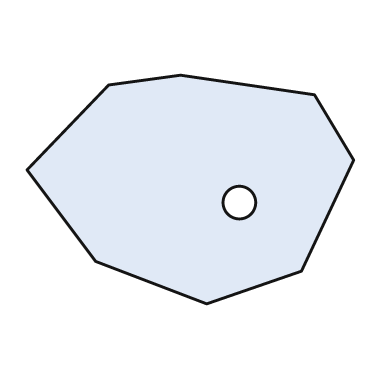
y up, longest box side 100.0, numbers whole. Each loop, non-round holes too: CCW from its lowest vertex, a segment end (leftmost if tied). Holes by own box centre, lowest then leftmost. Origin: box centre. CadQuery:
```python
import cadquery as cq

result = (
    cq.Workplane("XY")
    .moveTo(5.0, -35.0)
    .lineTo(34.0, -25.0)
    .lineTo(50.0, 9.0)
    .lineTo(38.0, 29.0)
    .lineTo(-3.0, 35.0)
    .lineTo(-25.0, 32.0)
    .lineTo(-50.0, 6.0)
    .lineTo(-29.0, -22.0)
    .close()
    .moveTo(15.0, -4.0)
    .circle(5.0)
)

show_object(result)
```